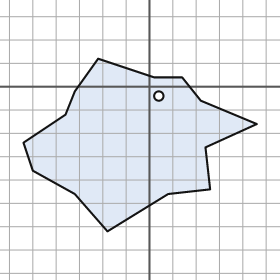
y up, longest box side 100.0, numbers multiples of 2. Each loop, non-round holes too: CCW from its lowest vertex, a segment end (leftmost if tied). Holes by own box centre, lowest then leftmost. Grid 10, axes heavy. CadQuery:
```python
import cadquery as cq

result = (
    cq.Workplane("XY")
    .moveTo(-18.0, -62.0)
    .lineTo(8.0, -46.0)
    .lineTo(26.0, -44.0)
    .lineTo(24.0, -26.0)
    .lineTo(46.0, -16.0)
    .lineTo(22.0, -6.0)
    .lineTo(14.0, 4.0)
    .lineTo(2.0, 4.0)
    .lineTo(-22.0, 12.0)
    .lineTo(-32.0, -2.0)
    .lineTo(-36.0, -12.0)
    .lineTo(-54.0, -24.0)
    .lineTo(-50.0, -36.0)
    .lineTo(-32.0, -46.0)
    .close()
    .moveTo(4.0, -4.0)
    .circle(2.0)
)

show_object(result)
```